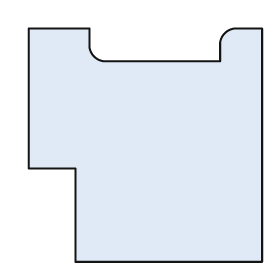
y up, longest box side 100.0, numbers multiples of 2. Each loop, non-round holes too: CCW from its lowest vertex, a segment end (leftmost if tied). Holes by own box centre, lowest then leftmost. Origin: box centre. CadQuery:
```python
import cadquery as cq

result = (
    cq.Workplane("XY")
    .moveTo(-30.0, -50.0)
    .lineTo(50.0, -50.0)
    .lineTo(50.0, 50.0)
    .lineTo(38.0, 50.0)
    .threePointArc((34.0, 48.0), (32.0, 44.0))
    .lineTo(32.0, 36.0)
    .lineTo(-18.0, 36.0)
    .threePointArc((-22.0, 38.0), (-24.0, 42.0))
    .lineTo(-24.0, 50.0)
    .lineTo(-50.0, 50.0)
    .lineTo(-50.0, -10.0)
    .lineTo(-30.0, -10.0)
    .close()
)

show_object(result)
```